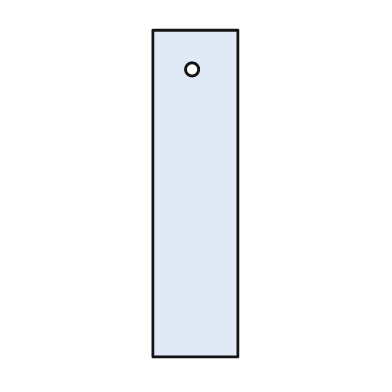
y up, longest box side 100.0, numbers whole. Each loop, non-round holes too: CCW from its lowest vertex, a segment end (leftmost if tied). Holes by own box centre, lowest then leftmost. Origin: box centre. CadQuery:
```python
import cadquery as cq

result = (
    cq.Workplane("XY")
    .moveTo(-13.0, -50.0)
    .lineTo(13.0, -50.0)
    .lineTo(13.0, 50.0)
    .lineTo(-13.0, 50.0)
    .close()
    .moveTo(-1.0, 38.0)
    .circle(2.0)
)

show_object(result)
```